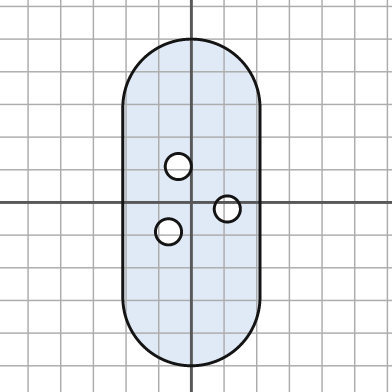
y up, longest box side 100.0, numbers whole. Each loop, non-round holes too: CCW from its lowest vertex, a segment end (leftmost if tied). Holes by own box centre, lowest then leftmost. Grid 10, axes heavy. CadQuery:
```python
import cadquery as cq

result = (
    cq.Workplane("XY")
    .moveTo(-21.0, -29.0)
    .threePointArc((0.0, -50.0), (21.0, -29.0))
    .lineTo(21.0, 29.0)
    .threePointArc((0.0, 50.0), (-21.0, 29.0))
    .close()
    .moveTo(-7.0, -9.0)
    .circle(4.0)
    .moveTo(11.0, -2.0)
    .circle(4.0)
    .moveTo(-4.0, 11.0)
    .circle(4.0)
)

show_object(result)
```